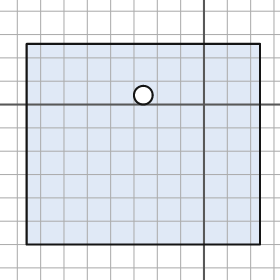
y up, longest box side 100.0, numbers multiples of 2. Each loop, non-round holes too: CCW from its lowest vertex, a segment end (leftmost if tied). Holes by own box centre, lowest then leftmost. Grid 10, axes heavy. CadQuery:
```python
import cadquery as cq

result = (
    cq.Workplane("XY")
    .moveTo(-76.0, -60.0)
    .lineTo(24.0, -60.0)
    .lineTo(24.0, 26.0)
    .lineTo(-76.0, 26.0)
    .close()
    .moveTo(-26.0, 4.0)
    .circle(4.0)
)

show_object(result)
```